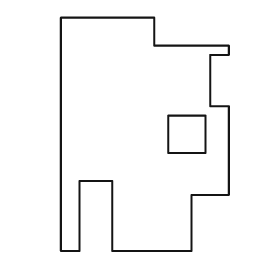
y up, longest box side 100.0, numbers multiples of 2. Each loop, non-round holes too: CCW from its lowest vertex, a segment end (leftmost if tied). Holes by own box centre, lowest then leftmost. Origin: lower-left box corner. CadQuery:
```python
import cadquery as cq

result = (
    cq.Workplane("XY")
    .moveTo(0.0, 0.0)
    .lineTo(8.0, 0.0)
    .lineTo(8.0, 30.0)
    .lineTo(22.0, 30.0)
    .lineTo(22.0, 0.0)
    .lineTo(56.0, 0.0)
    .lineTo(56.0, 24.0)
    .lineTo(72.0, 24.0)
    .lineTo(72.0, 62.0)
    .lineTo(64.0, 62.0)
    .lineTo(64.0, 84.0)
    .lineTo(72.0, 84.0)
    .lineTo(72.0, 88.0)
    .lineTo(40.0, 88.0)
    .lineTo(40.0, 100.0)
    .lineTo(0.0, 100.0)
    .close()
    .moveTo(46.0, 42.0)
    .lineTo(62.0, 42.0)
    .lineTo(62.0, 58.0)
    .lineTo(46.0, 58.0)
    .close()
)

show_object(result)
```